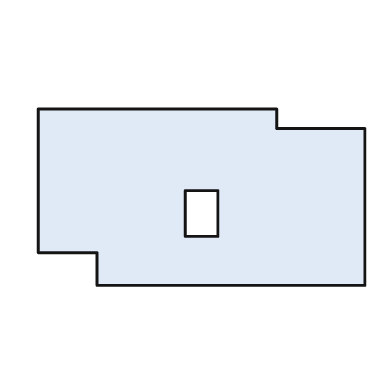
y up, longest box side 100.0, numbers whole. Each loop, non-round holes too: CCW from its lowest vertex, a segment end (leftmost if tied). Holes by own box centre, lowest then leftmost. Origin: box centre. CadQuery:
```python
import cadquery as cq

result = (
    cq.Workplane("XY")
    .moveTo(-32.0, -27.0)
    .lineTo(50.0, -27.0)
    .lineTo(50.0, 21.0)
    .lineTo(23.0, 21.0)
    .lineTo(23.0, 27.0)
    .lineTo(-50.0, 27.0)
    .lineTo(-50.0, -17.0)
    .lineTo(-32.0, -17.0)
    .close()
    .moveTo(-5.0, -12.0)
    .lineTo(5.0, -12.0)
    .lineTo(5.0, 2.0)
    .lineTo(-5.0, 2.0)
    .close()
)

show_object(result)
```